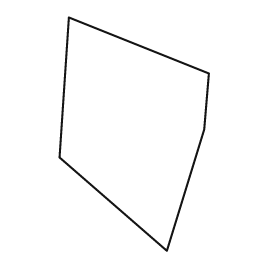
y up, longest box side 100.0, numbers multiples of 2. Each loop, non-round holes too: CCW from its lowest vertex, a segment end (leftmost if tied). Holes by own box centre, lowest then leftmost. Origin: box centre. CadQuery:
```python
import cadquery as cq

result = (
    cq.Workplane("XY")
    .moveTo(14.0, -50.0)
    .lineTo(30.0, 2.0)
    .lineTo(32.0, 26.0)
    .lineTo(-28.0, 50.0)
    .lineTo(-32.0, -10.0)
    .close()
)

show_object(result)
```